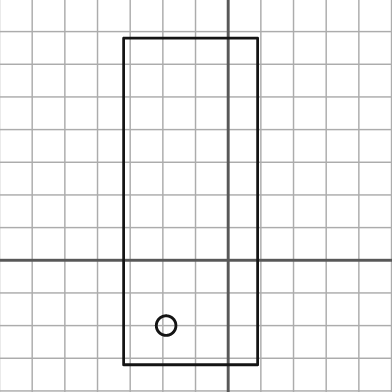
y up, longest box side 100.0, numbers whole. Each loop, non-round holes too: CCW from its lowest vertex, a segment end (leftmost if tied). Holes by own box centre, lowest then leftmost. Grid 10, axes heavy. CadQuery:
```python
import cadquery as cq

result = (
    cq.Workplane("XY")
    .moveTo(-32.0, -32.0)
    .lineTo(9.0, -32.0)
    .lineTo(9.0, 68.0)
    .lineTo(-32.0, 68.0)
    .close()
    .moveTo(-19.0, -20.0)
    .circle(3.0)
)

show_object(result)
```